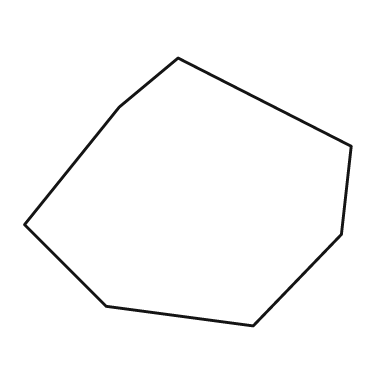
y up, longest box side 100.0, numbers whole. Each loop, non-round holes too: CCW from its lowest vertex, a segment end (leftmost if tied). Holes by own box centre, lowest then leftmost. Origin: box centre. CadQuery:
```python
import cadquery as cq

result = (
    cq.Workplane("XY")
    .moveTo(20.0, -41.0)
    .lineTo(47.0, -13.0)
    .lineTo(50.0, 14.0)
    .lineTo(-3.0, 41.0)
    .lineTo(-21.0, 26.0)
    .lineTo(-50.0, -10.0)
    .lineTo(-25.0, -35.0)
    .close()
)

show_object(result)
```